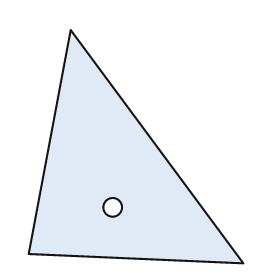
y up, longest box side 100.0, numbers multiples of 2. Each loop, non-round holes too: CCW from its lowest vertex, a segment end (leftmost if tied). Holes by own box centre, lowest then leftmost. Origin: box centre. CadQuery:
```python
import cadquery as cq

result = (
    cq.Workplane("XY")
    .moveTo(46.0, -50.0)
    .lineTo(-28.0, 50.0)
    .lineTo(-46.0, -46.0)
    .close()
    .moveTo(-10.0, -26.0)
    .circle(4.0)
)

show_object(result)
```